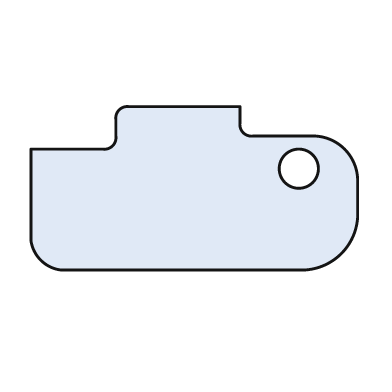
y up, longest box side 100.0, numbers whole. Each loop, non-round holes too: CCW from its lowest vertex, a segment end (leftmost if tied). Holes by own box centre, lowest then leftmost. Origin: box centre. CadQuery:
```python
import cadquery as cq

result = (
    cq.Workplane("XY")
    .moveTo(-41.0, -25.0)
    .lineTo(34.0, -25.0)
    .threePointArc((45.0, -20.0), (50.0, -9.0))
    .lineTo(50.0, 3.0)
    .threePointArc((46.0, 12.0), (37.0, 16.0))
    .lineTo(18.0, 16.0)
    .threePointArc((15.0, 17.0), (14.0, 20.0))
    .lineTo(14.0, 25.0)
    .lineTo(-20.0, 25.0)
    .threePointArc((-23.0, 24.0), (-24.0, 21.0))
    .lineTo(-24.0, 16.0)
    .threePointArc((-25.0, 13.0), (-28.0, 12.0))
    .lineTo(-50.0, 12.0)
    .lineTo(-50.0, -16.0)
    .threePointArc((-47.0, -22.0), (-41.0, -25.0))
    .close()
    .moveTo(32.0, 6.0)
    .circle(6.0)
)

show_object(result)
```